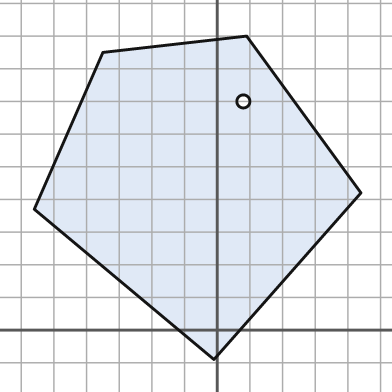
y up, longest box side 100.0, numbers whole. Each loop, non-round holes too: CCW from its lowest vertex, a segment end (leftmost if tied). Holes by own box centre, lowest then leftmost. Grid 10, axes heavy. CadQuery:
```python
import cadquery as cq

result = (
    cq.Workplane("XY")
    .moveTo(-1.0, -9.0)
    .lineTo(44.0, 42.0)
    .lineTo(9.0, 90.0)
    .lineTo(-35.0, 85.0)
    .lineTo(-56.0, 37.0)
    .close()
    .moveTo(8.0, 70.0)
    .circle(2.0)
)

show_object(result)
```